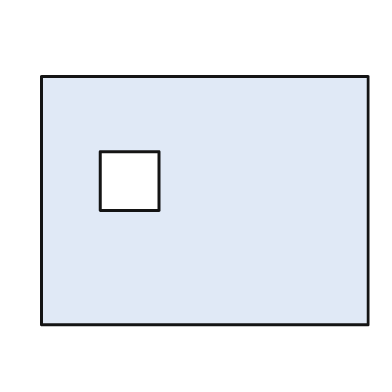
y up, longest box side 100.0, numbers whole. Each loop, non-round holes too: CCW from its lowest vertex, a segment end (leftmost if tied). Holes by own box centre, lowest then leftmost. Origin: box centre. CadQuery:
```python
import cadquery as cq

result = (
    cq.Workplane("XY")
    .moveTo(-50.0, -38.0)
    .lineTo(50.0, -38.0)
    .lineTo(50.0, 38.0)
    .lineTo(-50.0, 38.0)
    .close()
    .moveTo(-32.0, -3.0)
    .lineTo(-14.0, -3.0)
    .lineTo(-14.0, 15.0)
    .lineTo(-32.0, 15.0)
    .close()
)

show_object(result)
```